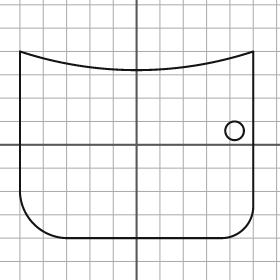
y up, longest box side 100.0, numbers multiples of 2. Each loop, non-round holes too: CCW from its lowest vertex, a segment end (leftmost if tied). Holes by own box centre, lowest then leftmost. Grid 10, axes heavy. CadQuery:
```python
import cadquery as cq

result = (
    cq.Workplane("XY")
    .moveTo(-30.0, -40.0)
    .lineTo(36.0, -40.0)
    .threePointArc((46.0, -36.0), (50.0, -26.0))
    .lineTo(50.0, 40.0)
    .threePointArc((0.0, 32.0), (-50.0, 40.0))
    .lineTo(-50.0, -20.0)
    .threePointArc((-44.0, -34.0), (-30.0, -40.0))
    .close()
    .moveTo(42.0, 6.0)
    .circle(4.0)
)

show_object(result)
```